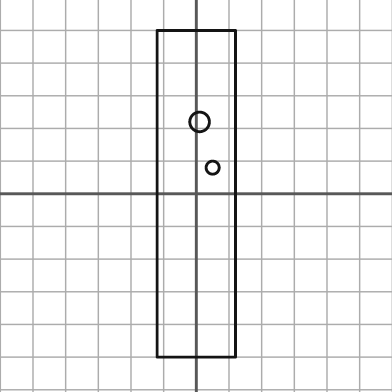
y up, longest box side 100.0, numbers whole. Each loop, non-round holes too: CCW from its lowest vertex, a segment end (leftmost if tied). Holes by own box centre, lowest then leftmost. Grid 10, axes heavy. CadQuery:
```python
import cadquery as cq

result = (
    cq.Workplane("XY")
    .moveTo(-12.0, -50.0)
    .lineTo(12.0, -50.0)
    .lineTo(12.0, 50.0)
    .lineTo(-12.0, 50.0)
    .close()
    .moveTo(5.0, 8.0)
    .circle(2.0)
    .moveTo(1.0, 22.0)
    .circle(3.0)
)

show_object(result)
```